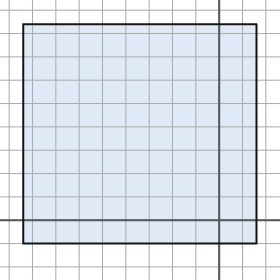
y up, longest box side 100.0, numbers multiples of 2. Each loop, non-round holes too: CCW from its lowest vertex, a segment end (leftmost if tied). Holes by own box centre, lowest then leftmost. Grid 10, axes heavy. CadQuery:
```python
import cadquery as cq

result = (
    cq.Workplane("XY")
    .moveTo(-84.0, -10.0)
    .lineTo(16.0, -10.0)
    .lineTo(16.0, 84.0)
    .lineTo(-84.0, 84.0)
    .close()
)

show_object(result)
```